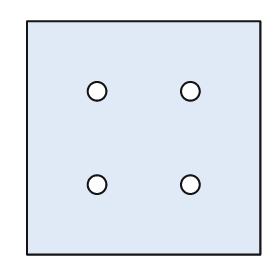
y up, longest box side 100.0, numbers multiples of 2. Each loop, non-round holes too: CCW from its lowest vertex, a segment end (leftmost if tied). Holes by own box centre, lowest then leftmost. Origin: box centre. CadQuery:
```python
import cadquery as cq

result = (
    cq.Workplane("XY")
    .moveTo(-50.0, -50.0)
    .lineTo(50.0, -50.0)
    .lineTo(50.0, 50.0)
    .lineTo(-50.0, 50.0)
    .close()
    .moveTo(-20.0, -20.0)
    .circle(4.0)
    .moveTo(20.0, -20.0)
    .circle(4.0)
    .moveTo(-20.0, 20.0)
    .circle(4.0)
    .moveTo(20.0, 20.0)
    .circle(4.0)
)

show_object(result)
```